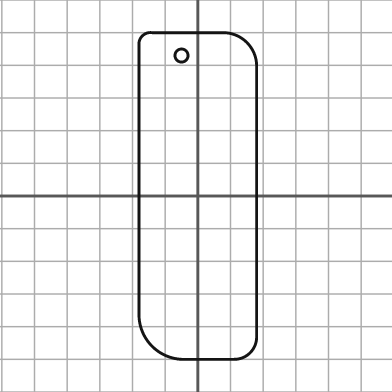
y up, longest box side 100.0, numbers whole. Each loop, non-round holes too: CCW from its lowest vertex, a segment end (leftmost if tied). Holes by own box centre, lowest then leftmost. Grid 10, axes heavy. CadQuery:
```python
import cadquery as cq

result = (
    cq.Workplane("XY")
    .moveTo(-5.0, -50.0)
    .lineTo(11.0, -50.0)
    .threePointArc((16.0, -48.0), (18.0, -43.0))
    .lineTo(18.0, 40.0)
    .threePointArc((15.0, 47.0), (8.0, 50.0))
    .lineTo(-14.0, 50.0)
    .threePointArc((-17.0, 49.0), (-18.0, 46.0))
    .lineTo(-18.0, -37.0)
    .threePointArc((-14.0, -46.0), (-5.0, -50.0))
    .close()
    .moveTo(-5.0, 43.0)
    .circle(2.0)
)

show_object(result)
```